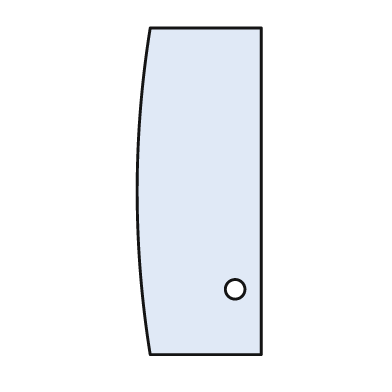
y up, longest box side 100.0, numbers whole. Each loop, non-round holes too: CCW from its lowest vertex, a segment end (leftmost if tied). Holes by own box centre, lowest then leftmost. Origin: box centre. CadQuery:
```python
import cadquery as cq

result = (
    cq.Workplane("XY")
    .moveTo(-15.0, -50.0)
    .lineTo(19.0, -50.0)
    .lineTo(19.0, 50.0)
    .lineTo(-15.0, 50.0)
    .threePointArc((-19.0, 0.0), (-15.0, -50.0))
    .close()
    .moveTo(11.0, -30.0)
    .circle(3.0)
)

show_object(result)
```